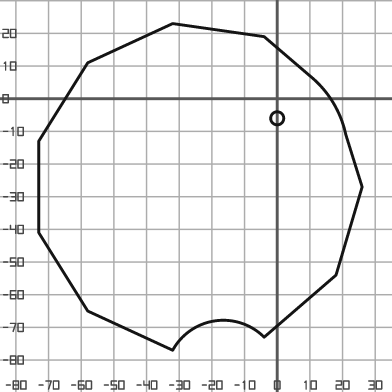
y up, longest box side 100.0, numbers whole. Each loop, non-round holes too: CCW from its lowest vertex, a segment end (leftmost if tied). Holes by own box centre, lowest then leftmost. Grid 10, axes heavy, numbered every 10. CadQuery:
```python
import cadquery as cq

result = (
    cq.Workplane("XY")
    .moveTo(-32.0, -77.0)
    .threePointArc((-19.0, -68.0), (-4.0, -73.0))
    .lineTo(18.0, -54.0)
    .lineTo(26.0, -27.0)
    .lineTo(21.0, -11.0)
    .threePointArc((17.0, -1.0), (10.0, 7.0))
    .lineTo(-4.0, 19.0)
    .lineTo(-32.0, 23.0)
    .lineTo(-58.0, 11.0)
    .lineTo(-73.0, -13.0)
    .lineTo(-73.0, -41.0)
    .lineTo(-58.0, -65.0)
    .close()
    .moveTo(0.0, -6.0)
    .circle(2.0)
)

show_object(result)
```